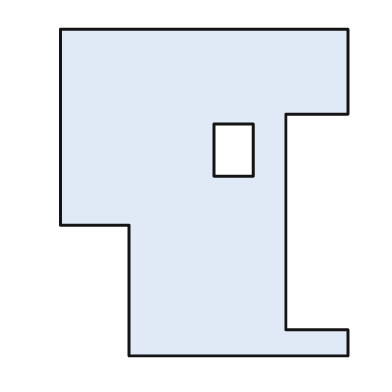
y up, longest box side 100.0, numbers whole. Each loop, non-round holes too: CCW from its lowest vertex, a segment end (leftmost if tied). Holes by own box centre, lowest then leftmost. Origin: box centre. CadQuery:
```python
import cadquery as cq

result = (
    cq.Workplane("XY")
    .moveTo(-23.0, -50.0)
    .lineTo(44.0, -50.0)
    .lineTo(44.0, -42.0)
    .lineTo(25.0, -42.0)
    .lineTo(25.0, 24.0)
    .lineTo(44.0, 24.0)
    .lineTo(44.0, 50.0)
    .lineTo(-44.0, 50.0)
    .lineTo(-44.0, -10.0)
    .lineTo(-23.0, -10.0)
    .close()
    .moveTo(3.0, 5.0)
    .lineTo(15.0, 5.0)
    .lineTo(15.0, 21.0)
    .lineTo(3.0, 21.0)
    .close()
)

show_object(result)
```